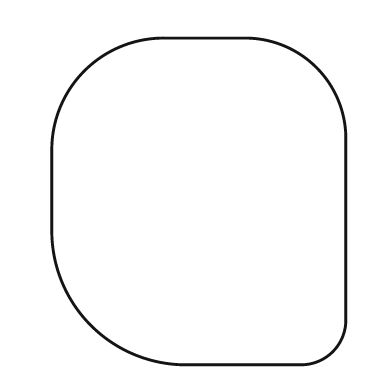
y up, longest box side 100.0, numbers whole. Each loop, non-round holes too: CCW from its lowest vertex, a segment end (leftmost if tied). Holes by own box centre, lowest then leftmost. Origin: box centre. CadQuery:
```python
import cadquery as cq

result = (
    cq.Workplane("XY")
    .moveTo(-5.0, -50.0)
    .lineTo(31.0, -50.0)
    .threePointArc((41.0, -46.0), (45.0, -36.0))
    .lineTo(45.0, 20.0)
    .threePointArc((36.0, 41.0), (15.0, 50.0))
    .lineTo(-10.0, 50.0)
    .threePointArc((-35.0, 40.0), (-45.0, 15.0))
    .lineTo(-45.0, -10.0)
    .threePointArc((-33.0, -38.0), (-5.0, -50.0))
    .close()
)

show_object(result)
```